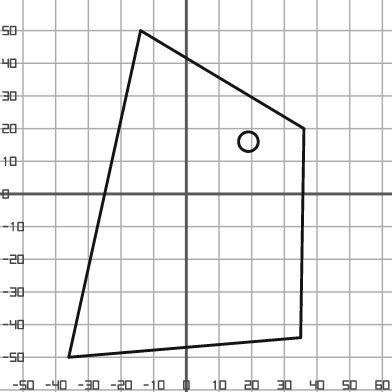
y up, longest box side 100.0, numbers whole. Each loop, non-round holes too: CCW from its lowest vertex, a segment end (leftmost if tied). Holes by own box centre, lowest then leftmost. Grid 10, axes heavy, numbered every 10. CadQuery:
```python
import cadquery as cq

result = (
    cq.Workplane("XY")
    .moveTo(-36.0, -50.0)
    .lineTo(35.0, -44.0)
    .lineTo(36.0, 20.0)
    .lineTo(-14.0, 50.0)
    .close()
    .moveTo(19.0, 16.0)
    .circle(3.0)
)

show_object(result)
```